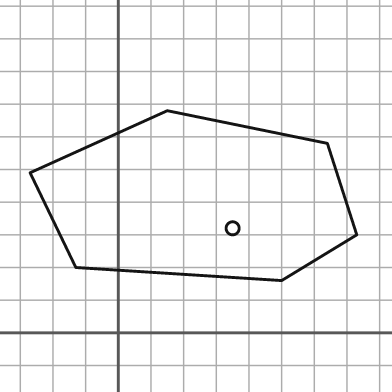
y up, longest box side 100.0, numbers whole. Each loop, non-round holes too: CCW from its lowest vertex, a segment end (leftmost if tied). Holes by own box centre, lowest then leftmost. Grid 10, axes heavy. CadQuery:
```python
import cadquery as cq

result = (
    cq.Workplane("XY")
    .moveTo(50.0, 16.0)
    .lineTo(73.0, 30.0)
    .lineTo(64.0, 58.0)
    .lineTo(15.0, 68.0)
    .lineTo(-27.0, 49.0)
    .lineTo(-13.0, 20.0)
    .close()
    .moveTo(35.0, 32.0)
    .circle(2.0)
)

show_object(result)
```